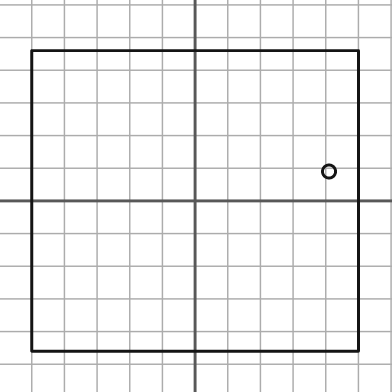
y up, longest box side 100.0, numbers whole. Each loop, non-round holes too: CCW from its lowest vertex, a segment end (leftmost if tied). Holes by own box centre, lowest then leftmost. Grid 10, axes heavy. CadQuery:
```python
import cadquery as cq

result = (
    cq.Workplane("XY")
    .moveTo(-50.0, -46.0)
    .lineTo(50.0, -46.0)
    .lineTo(50.0, 46.0)
    .lineTo(-50.0, 46.0)
    .close()
    .moveTo(41.0, 9.0)
    .circle(2.0)
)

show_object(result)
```